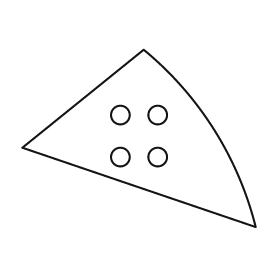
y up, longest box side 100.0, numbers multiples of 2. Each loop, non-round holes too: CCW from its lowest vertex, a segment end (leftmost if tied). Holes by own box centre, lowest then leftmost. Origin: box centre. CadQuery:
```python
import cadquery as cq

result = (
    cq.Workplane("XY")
    .moveTo(50.0, -38.0)
    .threePointArc((32.0, 4.0), (2.0, 38.0))
    .lineTo(-50.0, -4.0)
    .close()
    .moveTo(-8.0, -8.0)
    .circle(4.0)
    .moveTo(8.0, -8.0)
    .circle(4.0)
    .moveTo(-8.0, 10.0)
    .circle(4.0)
    .moveTo(8.0, 10.0)
    .circle(4.0)
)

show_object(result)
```